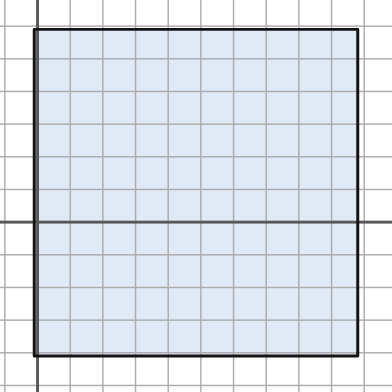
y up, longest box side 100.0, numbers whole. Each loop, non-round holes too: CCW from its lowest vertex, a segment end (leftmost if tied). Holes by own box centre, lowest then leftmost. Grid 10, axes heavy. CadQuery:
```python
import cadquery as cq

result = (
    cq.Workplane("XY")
    .moveTo(-1.0, -41.0)
    .lineTo(98.0, -41.0)
    .lineTo(98.0, 59.0)
    .lineTo(-1.0, 59.0)
    .close()
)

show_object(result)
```